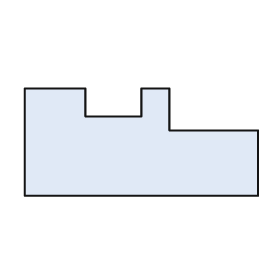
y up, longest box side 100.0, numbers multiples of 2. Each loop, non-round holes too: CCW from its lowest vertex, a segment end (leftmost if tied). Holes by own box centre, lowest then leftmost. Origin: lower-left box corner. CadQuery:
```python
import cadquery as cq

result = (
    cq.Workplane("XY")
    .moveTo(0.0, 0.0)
    .lineTo(100.0, 0.0)
    .lineTo(100.0, 28.0)
    .lineTo(62.0, 28.0)
    .lineTo(62.0, 46.0)
    .lineTo(50.0, 46.0)
    .lineTo(50.0, 34.0)
    .lineTo(26.0, 34.0)
    .lineTo(26.0, 46.0)
    .lineTo(0.0, 46.0)
    .close()
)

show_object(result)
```